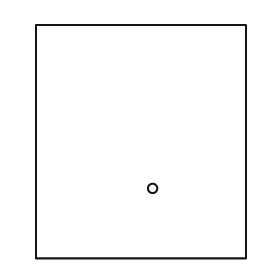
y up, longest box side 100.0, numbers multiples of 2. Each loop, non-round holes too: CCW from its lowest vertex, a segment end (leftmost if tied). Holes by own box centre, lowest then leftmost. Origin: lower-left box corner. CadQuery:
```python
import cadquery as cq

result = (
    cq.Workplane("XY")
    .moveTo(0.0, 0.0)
    .lineTo(90.0, 0.0)
    .lineTo(90.0, 100.0)
    .lineTo(0.0, 100.0)
    .close()
    .moveTo(50.0, 30.0)
    .circle(2.0)
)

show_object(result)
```